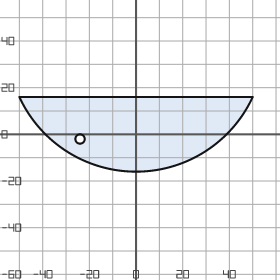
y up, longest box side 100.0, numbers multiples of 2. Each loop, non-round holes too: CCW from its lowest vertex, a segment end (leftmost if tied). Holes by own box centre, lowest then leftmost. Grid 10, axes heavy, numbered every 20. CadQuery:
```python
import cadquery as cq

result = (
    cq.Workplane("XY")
    .moveTo(-50.0, 16.0)
    .threePointArc((0.0, -16.0), (50.0, 16.0))
    .close()
    .moveTo(-24.0, -2.0)
    .circle(2.0)
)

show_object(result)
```